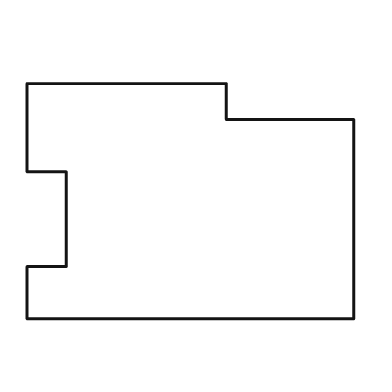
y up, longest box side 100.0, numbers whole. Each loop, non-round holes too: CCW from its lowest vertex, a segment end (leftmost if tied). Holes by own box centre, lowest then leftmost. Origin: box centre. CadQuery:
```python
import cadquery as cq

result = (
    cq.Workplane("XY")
    .moveTo(-50.0, -36.0)
    .lineTo(50.0, -36.0)
    .lineTo(50.0, 25.0)
    .lineTo(11.0, 25.0)
    .lineTo(11.0, 36.0)
    .lineTo(-50.0, 36.0)
    .lineTo(-50.0, 9.0)
    .lineTo(-38.0, 9.0)
    .lineTo(-38.0, -20.0)
    .lineTo(-50.0, -20.0)
    .close()
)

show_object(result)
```